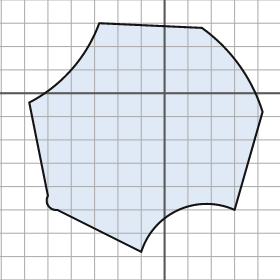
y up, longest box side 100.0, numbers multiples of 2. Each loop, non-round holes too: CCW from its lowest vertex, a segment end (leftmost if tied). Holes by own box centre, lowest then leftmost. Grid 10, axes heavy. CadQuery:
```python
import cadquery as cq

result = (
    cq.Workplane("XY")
    .moveTo(-10.0, -68.0)
    .threePointArc((6.0, -50.0), (30.0, -50.0))
    .lineTo(42.0, -8.0)
    .threePointArc((32.0, 12.0), (16.0, 28.0))
    .lineTo(-28.0, 30.0)
    .threePointArc((-40.0, 10.0), (-58.0, -4.0))
    .lineTo(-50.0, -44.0)
    .threePointArc((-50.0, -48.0), (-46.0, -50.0))
    .close()
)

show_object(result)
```